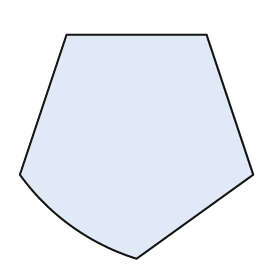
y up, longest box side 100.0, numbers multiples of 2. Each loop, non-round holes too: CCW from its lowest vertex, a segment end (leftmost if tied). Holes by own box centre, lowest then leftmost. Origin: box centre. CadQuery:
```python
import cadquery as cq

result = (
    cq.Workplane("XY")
    .moveTo(0.0, -48.0)
    .lineTo(50.0, -12.0)
    .lineTo(30.0, 48.0)
    .lineTo(-30.0, 48.0)
    .lineTo(-50.0, -12.0)
    .threePointArc((-28.0, -34.0), (0.0, -48.0))
    .close()
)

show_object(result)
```